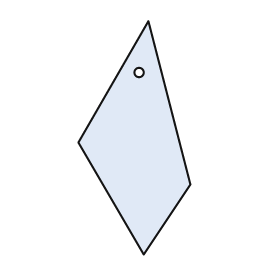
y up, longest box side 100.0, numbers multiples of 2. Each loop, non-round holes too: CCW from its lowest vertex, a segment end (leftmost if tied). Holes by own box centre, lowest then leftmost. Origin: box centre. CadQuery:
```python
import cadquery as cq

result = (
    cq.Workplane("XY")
    .moveTo(4.0, -50.0)
    .lineTo(24.0, -20.0)
    .lineTo(6.0, 50.0)
    .lineTo(-24.0, -2.0)
    .close()
    .moveTo(2.0, 28.0)
    .circle(2.0)
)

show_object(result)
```